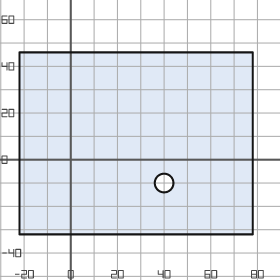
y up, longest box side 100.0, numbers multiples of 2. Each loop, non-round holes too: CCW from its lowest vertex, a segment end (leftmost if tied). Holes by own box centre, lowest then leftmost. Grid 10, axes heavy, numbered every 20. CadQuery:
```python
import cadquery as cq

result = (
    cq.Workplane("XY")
    .moveTo(-22.0, -32.0)
    .lineTo(78.0, -32.0)
    .lineTo(78.0, 46.0)
    .lineTo(-22.0, 46.0)
    .close()
    .moveTo(40.0, -10.0)
    .circle(4.0)
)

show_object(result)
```